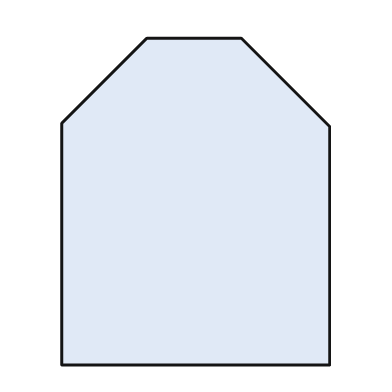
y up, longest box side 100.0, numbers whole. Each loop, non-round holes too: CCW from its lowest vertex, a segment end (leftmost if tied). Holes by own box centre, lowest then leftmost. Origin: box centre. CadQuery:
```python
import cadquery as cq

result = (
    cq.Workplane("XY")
    .moveTo(-41.0, -50.0)
    .lineTo(41.0, -50.0)
    .lineTo(41.0, 23.0)
    .lineTo(14.0, 50.0)
    .lineTo(-15.0, 50.0)
    .lineTo(-41.0, 24.0)
    .close()
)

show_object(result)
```